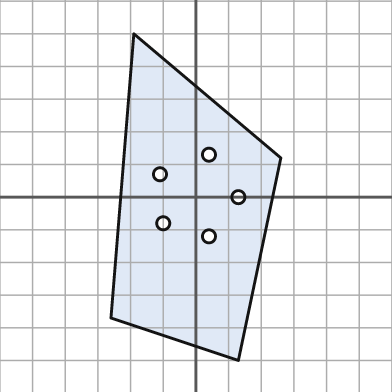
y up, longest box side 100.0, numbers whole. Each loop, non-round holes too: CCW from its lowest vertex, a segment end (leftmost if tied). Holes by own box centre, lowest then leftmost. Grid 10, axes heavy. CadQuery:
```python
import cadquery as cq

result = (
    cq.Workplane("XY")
    .moveTo(13.0, -50.0)
    .lineTo(26.0, 12.0)
    .lineTo(-19.0, 50.0)
    .lineTo(-26.0, -37.0)
    .close()
    .moveTo(4.0, -12.0)
    .circle(2.0)
    .moveTo(-10.0, -8.0)
    .circle(2.0)
    .moveTo(13.0, 0.0)
    .circle(2.0)
    .moveTo(-11.0, 7.0)
    .circle(2.0)
    .moveTo(4.0, 13.0)
    .circle(2.0)
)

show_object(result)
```